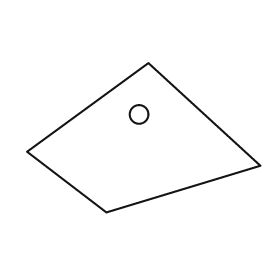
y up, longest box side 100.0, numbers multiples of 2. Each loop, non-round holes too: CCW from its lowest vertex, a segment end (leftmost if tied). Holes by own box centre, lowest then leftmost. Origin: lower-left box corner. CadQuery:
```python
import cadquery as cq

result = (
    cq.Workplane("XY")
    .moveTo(34.0, 0.0)
    .lineTo(100.0, 20.0)
    .lineTo(52.0, 64.0)
    .lineTo(0.0, 26.0)
    .close()
    .moveTo(48.0, 42.0)
    .circle(4.0)
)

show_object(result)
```